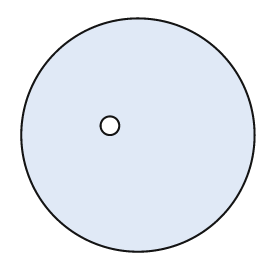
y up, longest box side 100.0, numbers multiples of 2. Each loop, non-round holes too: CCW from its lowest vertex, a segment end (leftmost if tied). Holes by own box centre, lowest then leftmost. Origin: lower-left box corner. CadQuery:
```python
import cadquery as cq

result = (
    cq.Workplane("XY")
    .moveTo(50.0, 50.0)
    .circle(50.0)
    .moveTo(38.0, 54.0)
    .circle(4.0)
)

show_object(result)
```